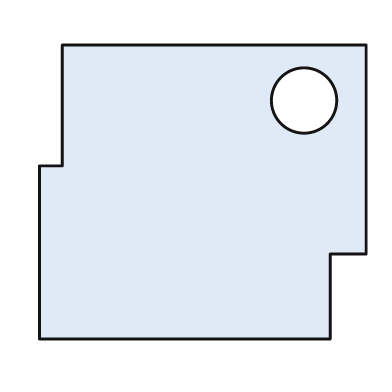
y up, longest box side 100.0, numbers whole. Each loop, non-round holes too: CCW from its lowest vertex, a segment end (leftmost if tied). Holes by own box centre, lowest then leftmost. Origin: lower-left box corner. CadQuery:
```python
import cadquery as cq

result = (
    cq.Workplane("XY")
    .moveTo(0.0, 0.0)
    .lineTo(89.0, 0.0)
    .lineTo(89.0, 26.0)
    .lineTo(100.0, 26.0)
    .lineTo(100.0, 90.0)
    .lineTo(7.0, 90.0)
    .lineTo(7.0, 53.0)
    .lineTo(0.0, 53.0)
    .close()
    .moveTo(81.0, 73.0)
    .circle(10.0)
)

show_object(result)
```